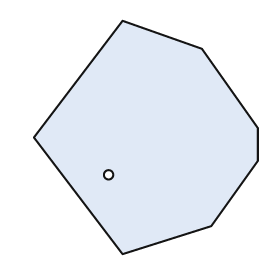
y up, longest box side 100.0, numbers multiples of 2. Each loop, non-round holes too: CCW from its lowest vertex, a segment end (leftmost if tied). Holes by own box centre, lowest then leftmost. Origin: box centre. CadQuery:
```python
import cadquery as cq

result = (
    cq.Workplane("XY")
    .moveTo(-10.0, -50.0)
    .lineTo(28.0, -38.0)
    .lineTo(48.0, -10.0)
    .lineTo(48.0, 4.0)
    .lineTo(24.0, 38.0)
    .lineTo(-10.0, 50.0)
    .lineTo(-48.0, 0.0)
    .close()
    .moveTo(-16.0, -16.0)
    .circle(2.0)
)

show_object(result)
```